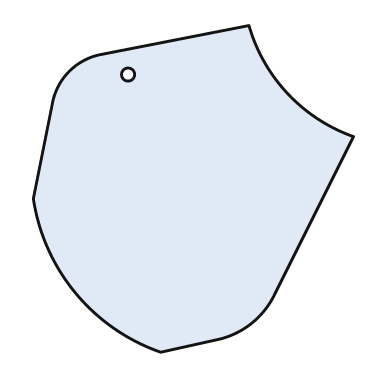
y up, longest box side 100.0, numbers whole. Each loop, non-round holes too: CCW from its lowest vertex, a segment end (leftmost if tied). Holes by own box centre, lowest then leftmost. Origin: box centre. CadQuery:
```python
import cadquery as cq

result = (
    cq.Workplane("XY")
    .moveTo(-10.0, -50.0)
    .lineTo(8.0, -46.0)
    .threePointArc((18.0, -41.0), (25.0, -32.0))
    .lineTo(49.0, 16.0)
    .threePointArc((29.0, 29.0), (17.0, 50.0))
    .lineTo(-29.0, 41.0)
    .threePointArc((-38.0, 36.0), (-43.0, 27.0))
    .lineTo(-49.0, -3.0)
    .threePointArc((-36.0, -32.0), (-10.0, -50.0))
    .close()
    .moveTo(-20.0, 35.0)
    .circle(2.0)
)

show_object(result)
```